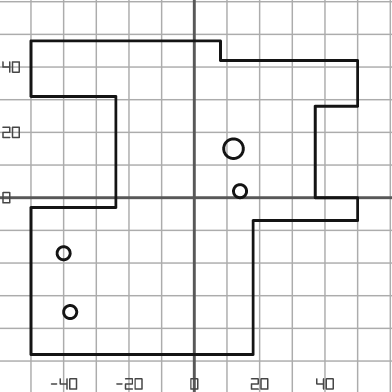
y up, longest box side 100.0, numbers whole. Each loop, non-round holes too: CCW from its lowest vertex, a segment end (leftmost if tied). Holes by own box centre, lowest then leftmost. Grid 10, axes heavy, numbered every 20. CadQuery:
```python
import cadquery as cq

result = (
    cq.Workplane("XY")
    .moveTo(-50.0, -48.0)
    .lineTo(18.0, -48.0)
    .lineTo(18.0, -7.0)
    .lineTo(50.0, -7.0)
    .lineTo(50.0, 0.0)
    .lineTo(37.0, 0.0)
    .lineTo(37.0, 28.0)
    .lineTo(50.0, 28.0)
    .lineTo(50.0, 42.0)
    .lineTo(8.0, 42.0)
    .lineTo(8.0, 48.0)
    .lineTo(-50.0, 48.0)
    .lineTo(-50.0, 31.0)
    .lineTo(-24.0, 31.0)
    .lineTo(-24.0, -3.0)
    .lineTo(-50.0, -3.0)
    .close()
    .moveTo(-38.0, -35.0)
    .circle(2.0)
    .moveTo(-40.0, -17.0)
    .circle(2.0)
    .moveTo(14.0, 2.0)
    .circle(2.0)
    .moveTo(12.0, 15.0)
    .circle(3.0)
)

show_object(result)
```